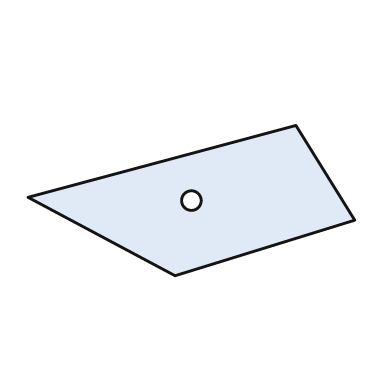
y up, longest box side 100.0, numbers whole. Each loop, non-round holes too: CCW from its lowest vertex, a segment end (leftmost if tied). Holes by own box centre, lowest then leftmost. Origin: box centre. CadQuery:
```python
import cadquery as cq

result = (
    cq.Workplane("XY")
    .moveTo(-5.0, -23.0)
    .lineTo(50.0, -6.0)
    .lineTo(32.0, 23.0)
    .lineTo(-50.0, 1.0)
    .close()
    .moveTo(0.0, 0.0)
    .circle(3.0)
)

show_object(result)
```